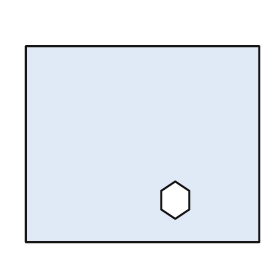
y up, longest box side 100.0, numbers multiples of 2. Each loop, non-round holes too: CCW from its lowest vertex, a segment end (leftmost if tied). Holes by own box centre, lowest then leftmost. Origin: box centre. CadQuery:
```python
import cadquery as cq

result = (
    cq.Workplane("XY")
    .moveTo(-50.0, -42.0)
    .lineTo(50.0, -42.0)
    .lineTo(50.0, 42.0)
    .lineTo(-50.0, 42.0)
    .close()
    .moveTo(14.0, -32.0)
    .lineTo(20.0, -28.0)
    .lineTo(20.0, -20.0)
    .lineTo(14.0, -16.0)
    .lineTo(8.0, -20.0)
    .lineTo(8.0, -28.0)
    .close()
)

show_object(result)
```